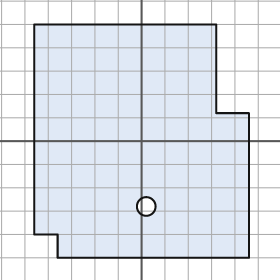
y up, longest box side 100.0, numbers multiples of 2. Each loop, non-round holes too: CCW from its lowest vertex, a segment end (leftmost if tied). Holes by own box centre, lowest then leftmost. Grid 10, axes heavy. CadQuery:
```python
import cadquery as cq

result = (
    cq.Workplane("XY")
    .moveTo(-36.0, -50.0)
    .lineTo(46.0, -50.0)
    .lineTo(46.0, 12.0)
    .lineTo(32.0, 12.0)
    .lineTo(32.0, 50.0)
    .lineTo(-46.0, 50.0)
    .lineTo(-46.0, -40.0)
    .lineTo(-36.0, -40.0)
    .close()
    .moveTo(2.0, -28.0)
    .circle(4.0)
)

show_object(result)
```